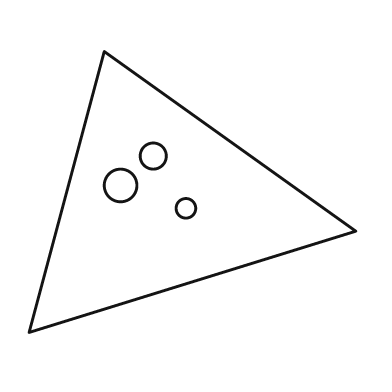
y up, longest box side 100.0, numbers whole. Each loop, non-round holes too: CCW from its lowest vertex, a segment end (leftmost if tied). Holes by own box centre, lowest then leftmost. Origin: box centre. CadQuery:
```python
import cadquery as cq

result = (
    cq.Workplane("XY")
    .moveTo(-50.0, -43.0)
    .lineTo(50.0, -12.0)
    .lineTo(-27.0, 43.0)
    .close()
    .moveTo(-2.0, -5.0)
    .circle(3.0)
    .moveTo(-22.0, 2.0)
    .circle(5.0)
    .moveTo(-12.0, 11.0)
    .circle(4.0)
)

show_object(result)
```